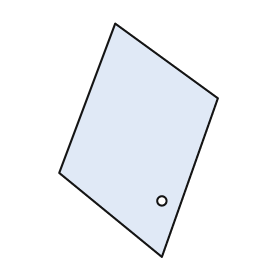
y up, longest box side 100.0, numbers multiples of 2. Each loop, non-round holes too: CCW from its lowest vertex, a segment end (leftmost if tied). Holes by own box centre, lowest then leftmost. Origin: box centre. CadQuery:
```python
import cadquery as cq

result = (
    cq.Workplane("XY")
    .moveTo(10.0, -50.0)
    .lineTo(34.0, 18.0)
    .lineTo(-10.0, 50.0)
    .lineTo(-34.0, -14.0)
    .close()
    .moveTo(10.0, -26.0)
    .circle(2.0)
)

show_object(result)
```